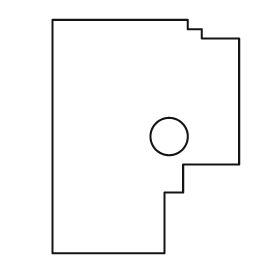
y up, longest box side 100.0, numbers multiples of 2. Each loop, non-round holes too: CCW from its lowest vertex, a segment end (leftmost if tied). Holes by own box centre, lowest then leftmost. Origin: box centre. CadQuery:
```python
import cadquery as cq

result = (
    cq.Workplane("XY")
    .moveTo(-40.0, -50.0)
    .lineTo(8.0, -50.0)
    .lineTo(8.0, -24.0)
    .lineTo(16.0, -24.0)
    .lineTo(16.0, -12.0)
    .lineTo(40.0, -12.0)
    .lineTo(40.0, 42.0)
    .lineTo(24.0, 42.0)
    .lineTo(24.0, 46.0)
    .lineTo(18.0, 46.0)
    .lineTo(18.0, 50.0)
    .lineTo(-40.0, 50.0)
    .close()
    .moveTo(10.0, 0.0)
    .circle(8.0)
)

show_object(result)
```